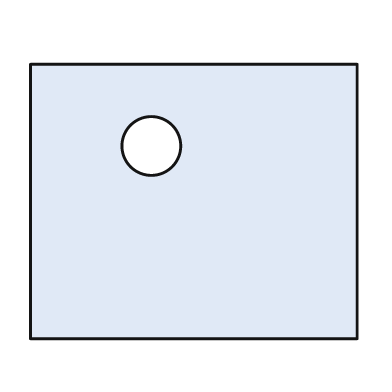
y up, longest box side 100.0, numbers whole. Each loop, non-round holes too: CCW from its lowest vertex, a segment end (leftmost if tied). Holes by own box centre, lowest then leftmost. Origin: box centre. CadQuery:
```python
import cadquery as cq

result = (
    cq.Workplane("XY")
    .moveTo(-50.0, -42.0)
    .lineTo(50.0, -42.0)
    .lineTo(50.0, 42.0)
    .lineTo(-50.0, 42.0)
    .close()
    .moveTo(-13.0, 17.0)
    .circle(9.0)
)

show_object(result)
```